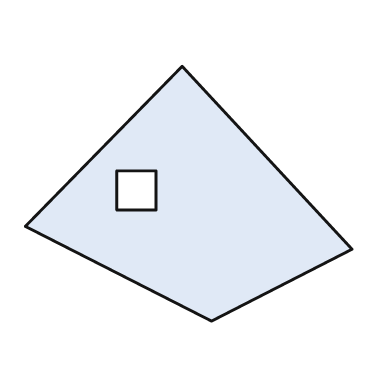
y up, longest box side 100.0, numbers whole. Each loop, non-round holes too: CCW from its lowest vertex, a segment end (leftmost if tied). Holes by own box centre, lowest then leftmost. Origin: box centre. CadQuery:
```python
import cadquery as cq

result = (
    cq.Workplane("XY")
    .moveTo(7.0, -39.0)
    .lineTo(50.0, -17.0)
    .lineTo(-2.0, 39.0)
    .lineTo(-50.0, -10.0)
    .close()
    .moveTo(-22.0, -5.0)
    .lineTo(-10.0, -5.0)
    .lineTo(-10.0, 7.0)
    .lineTo(-22.0, 7.0)
    .close()
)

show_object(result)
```